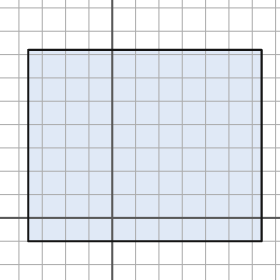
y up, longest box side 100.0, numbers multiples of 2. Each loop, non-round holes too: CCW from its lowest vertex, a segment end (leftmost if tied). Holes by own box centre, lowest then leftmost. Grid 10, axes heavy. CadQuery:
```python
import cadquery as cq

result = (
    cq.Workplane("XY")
    .moveTo(-36.0, -10.0)
    .lineTo(64.0, -10.0)
    .lineTo(64.0, 72.0)
    .lineTo(-36.0, 72.0)
    .close()
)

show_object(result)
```